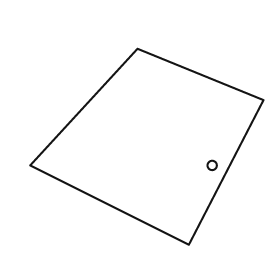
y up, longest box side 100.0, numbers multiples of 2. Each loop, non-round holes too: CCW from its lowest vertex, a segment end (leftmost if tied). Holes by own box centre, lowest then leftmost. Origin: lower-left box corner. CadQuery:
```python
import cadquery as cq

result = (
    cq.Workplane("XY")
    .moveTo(68.0, 0.0)
    .lineTo(100.0, 62.0)
    .lineTo(46.0, 84.0)
    .lineTo(0.0, 34.0)
    .close()
    .moveTo(78.0, 34.0)
    .circle(2.0)
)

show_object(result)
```